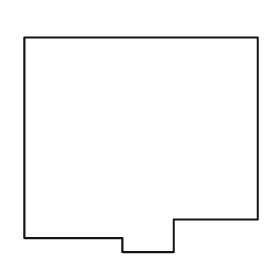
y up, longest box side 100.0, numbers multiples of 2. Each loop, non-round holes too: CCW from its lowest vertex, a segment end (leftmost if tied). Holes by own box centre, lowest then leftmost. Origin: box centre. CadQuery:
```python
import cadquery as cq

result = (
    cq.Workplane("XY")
    .moveTo(-8.0, -46.0)
    .lineTo(14.0, -46.0)
    .lineTo(14.0, -32.0)
    .lineTo(50.0, -32.0)
    .lineTo(50.0, 46.0)
    .lineTo(-50.0, 46.0)
    .lineTo(-50.0, -40.0)
    .lineTo(-8.0, -40.0)
    .close()
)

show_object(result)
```